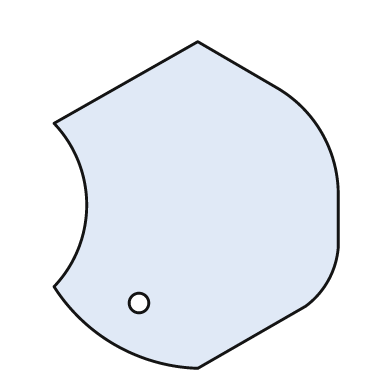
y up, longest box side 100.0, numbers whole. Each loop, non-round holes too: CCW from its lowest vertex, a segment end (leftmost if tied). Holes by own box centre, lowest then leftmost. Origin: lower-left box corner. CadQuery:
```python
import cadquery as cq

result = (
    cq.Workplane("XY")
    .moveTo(44.0, 0.0)
    .lineTo(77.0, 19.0)
    .threePointArc((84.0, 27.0), (87.0, 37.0))
    .lineTo(87.0, 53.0)
    .threePointArc((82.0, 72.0), (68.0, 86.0))
    .lineTo(44.0, 100.0)
    .lineTo(0.0, 75.0)
    .threePointArc((10.0, 50.0), (0.0, 25.0))
    .threePointArc((19.0, 7.0), (44.0, 0.0))
    .close()
    .moveTo(26.0, 20.0)
    .circle(3.0)
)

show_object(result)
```